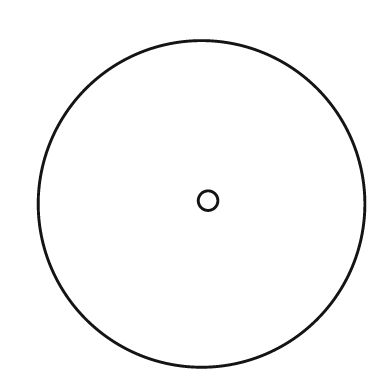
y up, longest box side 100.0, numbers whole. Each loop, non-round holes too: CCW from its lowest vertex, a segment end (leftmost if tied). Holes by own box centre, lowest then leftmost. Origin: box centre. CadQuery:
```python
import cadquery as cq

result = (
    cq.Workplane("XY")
    .moveTo(0.0, 0.0)
    .circle(50.0)
    .moveTo(2.0, 1.0)
    .circle(3.0)
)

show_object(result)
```